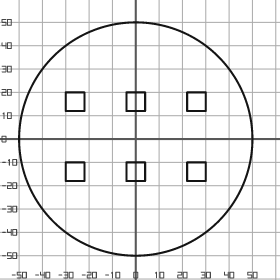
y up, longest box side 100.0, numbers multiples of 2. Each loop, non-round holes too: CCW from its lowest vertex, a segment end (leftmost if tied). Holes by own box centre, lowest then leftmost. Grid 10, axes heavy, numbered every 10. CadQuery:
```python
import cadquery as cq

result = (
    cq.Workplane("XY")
    .moveTo(0.0, 0.0)
    .circle(50.0)
    .moveTo(-30.0, -18.0)
    .lineTo(-22.0, -18.0)
    .lineTo(-22.0, -10.0)
    .lineTo(-30.0, -10.0)
    .close()
    .moveTo(-4.0, -18.0)
    .lineTo(4.0, -18.0)
    .lineTo(4.0, -10.0)
    .lineTo(-4.0, -10.0)
    .close()
    .moveTo(22.0, -18.0)
    .lineTo(30.0, -18.0)
    .lineTo(30.0, -10.0)
    .lineTo(22.0, -10.0)
    .close()
    .moveTo(-30.0, 12.0)
    .lineTo(-22.0, 12.0)
    .lineTo(-22.0, 20.0)
    .lineTo(-30.0, 20.0)
    .close()
    .moveTo(-4.0, 12.0)
    .lineTo(4.0, 12.0)
    .lineTo(4.0, 20.0)
    .lineTo(-4.0, 20.0)
    .close()
    .moveTo(22.0, 12.0)
    .lineTo(30.0, 12.0)
    .lineTo(30.0, 20.0)
    .lineTo(22.0, 20.0)
    .close()
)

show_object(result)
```